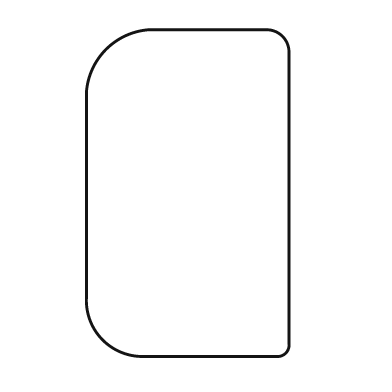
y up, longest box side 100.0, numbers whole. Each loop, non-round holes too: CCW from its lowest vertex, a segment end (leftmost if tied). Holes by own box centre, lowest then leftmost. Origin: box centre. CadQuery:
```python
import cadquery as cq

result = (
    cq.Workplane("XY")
    .moveTo(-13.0, -50.0)
    .lineTo(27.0, -50.0)
    .threePointArc((30.0, -49.0), (31.0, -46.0))
    .lineTo(31.0, 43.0)
    .threePointArc((29.0, 48.0), (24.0, 50.0))
    .lineTo(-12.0, 50.0)
    .threePointArc((-25.0, 44.0), (-31.0, 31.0))
    .lineTo(-31.0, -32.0)
    .threePointArc((-26.0, -45.0), (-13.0, -50.0))
    .close()
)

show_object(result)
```